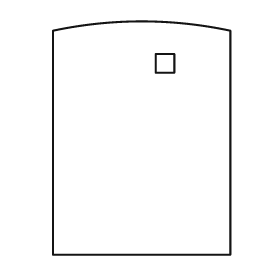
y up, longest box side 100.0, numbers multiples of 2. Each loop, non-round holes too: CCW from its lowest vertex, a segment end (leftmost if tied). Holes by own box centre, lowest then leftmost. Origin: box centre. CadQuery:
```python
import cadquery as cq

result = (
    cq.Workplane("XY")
    .moveTo(-38.0, -50.0)
    .lineTo(38.0, -50.0)
    .lineTo(38.0, 46.0)
    .threePointArc((0.0, 50.0), (-38.0, 46.0))
    .close()
    .moveTo(6.0, 28.0)
    .lineTo(14.0, 28.0)
    .lineTo(14.0, 36.0)
    .lineTo(6.0, 36.0)
    .close()
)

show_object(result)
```